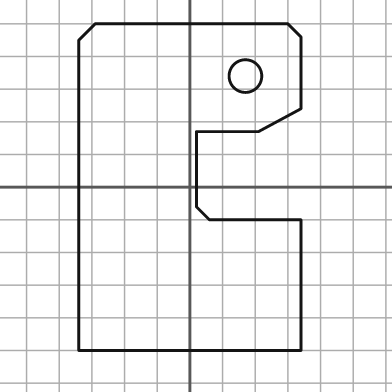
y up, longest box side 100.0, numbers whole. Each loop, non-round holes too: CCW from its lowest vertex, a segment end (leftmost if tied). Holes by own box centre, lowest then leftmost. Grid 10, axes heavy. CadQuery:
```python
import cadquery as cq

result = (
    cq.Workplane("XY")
    .moveTo(-34.0, -50.0)
    .lineTo(34.0, -50.0)
    .lineTo(34.0, -10.0)
    .lineTo(6.0, -10.0)
    .lineTo(2.0, -6.0)
    .lineTo(2.0, 17.0)
    .lineTo(21.0, 17.0)
    .lineTo(34.0, 24.0)
    .lineTo(34.0, 46.0)
    .lineTo(30.0, 50.0)
    .lineTo(-29.0, 50.0)
    .lineTo(-34.0, 45.0)
    .close()
    .moveTo(17.0, 34.0)
    .circle(5.0)
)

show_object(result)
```